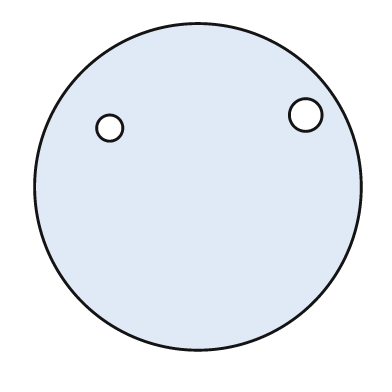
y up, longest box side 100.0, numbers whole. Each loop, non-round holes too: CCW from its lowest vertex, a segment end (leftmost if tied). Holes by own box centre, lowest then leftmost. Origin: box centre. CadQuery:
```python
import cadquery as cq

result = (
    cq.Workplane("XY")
    .moveTo(0.0, 0.0)
    .circle(50.0)
    .moveTo(-27.0, 18.0)
    .circle(4.0)
    .moveTo(33.0, 22.0)
    .circle(5.0)
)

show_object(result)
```